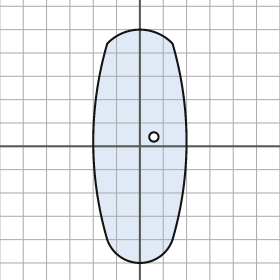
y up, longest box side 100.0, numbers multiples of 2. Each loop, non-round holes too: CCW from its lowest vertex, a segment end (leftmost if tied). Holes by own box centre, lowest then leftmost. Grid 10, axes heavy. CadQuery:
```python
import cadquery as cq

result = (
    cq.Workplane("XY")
    .moveTo(-14.0, -40.0)
    .threePointArc((0.0, -50.0), (14.0, -40.0))
    .threePointArc((20.0, 2.0), (14.0, 44.0))
    .threePointArc((0.0, 50.0), (-14.0, 44.0))
    .threePointArc((-20.0, 2.0), (-14.0, -40.0))
    .close()
    .moveTo(6.0, 4.0)
    .circle(2.0)
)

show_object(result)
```